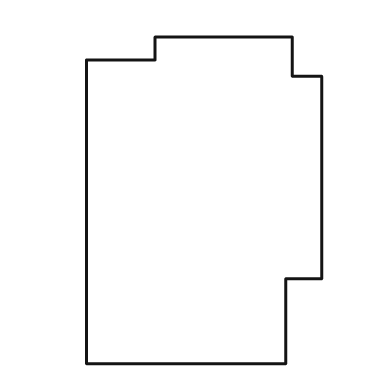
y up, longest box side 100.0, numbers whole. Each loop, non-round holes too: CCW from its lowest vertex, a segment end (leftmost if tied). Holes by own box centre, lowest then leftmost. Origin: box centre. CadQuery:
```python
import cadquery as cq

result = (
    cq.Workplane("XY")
    .moveTo(-36.0, -50.0)
    .lineTo(25.0, -50.0)
    .lineTo(25.0, -24.0)
    .lineTo(36.0, -24.0)
    .lineTo(36.0, 38.0)
    .lineTo(27.0, 38.0)
    .lineTo(27.0, 50.0)
    .lineTo(-15.0, 50.0)
    .lineTo(-15.0, 43.0)
    .lineTo(-36.0, 43.0)
    .close()
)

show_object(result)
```